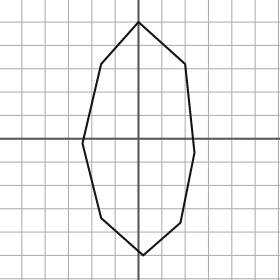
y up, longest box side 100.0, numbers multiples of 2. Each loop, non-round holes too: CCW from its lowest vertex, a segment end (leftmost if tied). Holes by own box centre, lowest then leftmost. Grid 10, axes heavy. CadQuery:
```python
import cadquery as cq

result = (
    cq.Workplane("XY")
    .moveTo(2.0, -50.0)
    .lineTo(18.0, -36.0)
    .lineTo(24.0, -6.0)
    .lineTo(20.0, 32.0)
    .lineTo(0.0, 50.0)
    .lineTo(-16.0, 32.0)
    .lineTo(-24.0, -2.0)
    .lineTo(-16.0, -34.0)
    .close()
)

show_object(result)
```